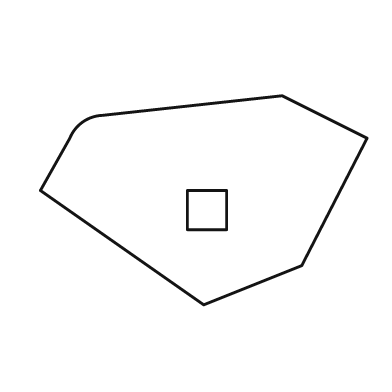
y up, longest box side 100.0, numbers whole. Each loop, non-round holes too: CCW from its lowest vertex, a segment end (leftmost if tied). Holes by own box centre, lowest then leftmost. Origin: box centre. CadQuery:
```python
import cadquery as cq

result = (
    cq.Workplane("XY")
    .moveTo(0.0, -32.0)
    .lineTo(30.0, -20.0)
    .lineTo(50.0, 19.0)
    .lineTo(24.0, 32.0)
    .lineTo(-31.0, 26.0)
    .threePointArc((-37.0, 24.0), (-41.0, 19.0))
    .lineTo(-50.0, 3.0)
    .close()
    .moveTo(-5.0, -9.0)
    .lineTo(7.0, -9.0)
    .lineTo(7.0, 3.0)
    .lineTo(-5.0, 3.0)
    .close()
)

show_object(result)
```